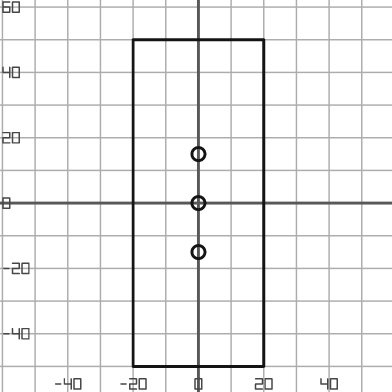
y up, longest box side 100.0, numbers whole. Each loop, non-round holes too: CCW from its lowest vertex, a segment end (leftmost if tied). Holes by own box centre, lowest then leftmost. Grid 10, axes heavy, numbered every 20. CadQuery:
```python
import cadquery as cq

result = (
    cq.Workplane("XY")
    .moveTo(-20.0, -50.0)
    .lineTo(20.0, -50.0)
    .lineTo(20.0, 50.0)
    .lineTo(-20.0, 50.0)
    .close()
    .moveTo(0.0, -15.0)
    .circle(2.0)
    .moveTo(0.0, 0.0)
    .circle(2.0)
    .moveTo(0.0, 15.0)
    .circle(2.0)
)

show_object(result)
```